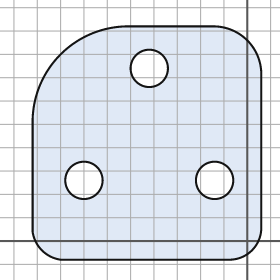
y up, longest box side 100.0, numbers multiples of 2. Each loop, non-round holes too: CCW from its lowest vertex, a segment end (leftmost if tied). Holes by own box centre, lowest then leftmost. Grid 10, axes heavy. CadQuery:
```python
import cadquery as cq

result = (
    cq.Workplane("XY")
    .moveTo(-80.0, -8.0)
    .lineTo(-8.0, -8.0)
    .threePointArc((2.0, -4.0), (6.0, 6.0))
    .lineTo(6.0, 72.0)
    .threePointArc((0.0, 86.0), (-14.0, 92.0))
    .lineTo(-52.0, 92.0)
    .threePointArc((-80.0, 80.0), (-92.0, 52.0))
    .lineTo(-92.0, 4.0)
    .threePointArc((-88.0, -4.0), (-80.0, -8.0))
    .close()
    .moveTo(-70.0, 26.0)
    .circle(8.0)
    .moveTo(-14.0, 26.0)
    .circle(8.0)
    .moveTo(-42.0, 74.0)
    .circle(8.0)
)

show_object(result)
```